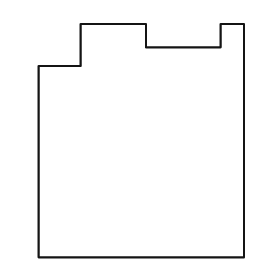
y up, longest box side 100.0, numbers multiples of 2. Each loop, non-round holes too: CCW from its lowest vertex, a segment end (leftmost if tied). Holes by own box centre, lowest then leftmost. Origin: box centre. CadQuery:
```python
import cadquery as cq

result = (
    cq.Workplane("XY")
    .moveTo(-44.0, -50.0)
    .lineTo(44.0, -50.0)
    .lineTo(44.0, 50.0)
    .lineTo(34.0, 50.0)
    .lineTo(34.0, 40.0)
    .lineTo(2.0, 40.0)
    .lineTo(2.0, 50.0)
    .lineTo(-26.0, 50.0)
    .lineTo(-26.0, 32.0)
    .lineTo(-44.0, 32.0)
    .close()
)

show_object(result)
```